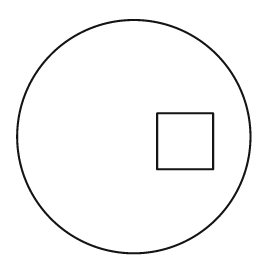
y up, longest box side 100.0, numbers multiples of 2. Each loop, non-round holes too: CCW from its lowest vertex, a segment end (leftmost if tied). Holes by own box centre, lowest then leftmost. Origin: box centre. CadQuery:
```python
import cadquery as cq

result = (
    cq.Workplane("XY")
    .moveTo(0.0, 0.0)
    .circle(50.0)
    .moveTo(10.0, -14.0)
    .lineTo(34.0, -14.0)
    .lineTo(34.0, 10.0)
    .lineTo(10.0, 10.0)
    .close()
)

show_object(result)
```